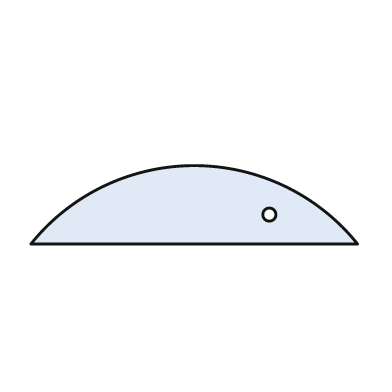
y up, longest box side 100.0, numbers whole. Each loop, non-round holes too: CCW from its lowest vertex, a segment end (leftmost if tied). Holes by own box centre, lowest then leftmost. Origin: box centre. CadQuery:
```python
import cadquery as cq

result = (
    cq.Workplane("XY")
    .moveTo(-50.0, -12.0)
    .lineTo(50.0, -12.0)
    .threePointArc((0.0, 12.0), (-50.0, -12.0))
    .close()
    .moveTo(23.0, -3.0)
    .circle(2.0)
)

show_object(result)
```